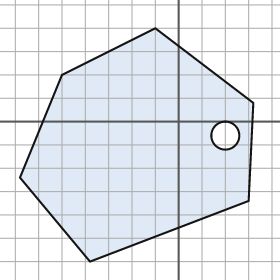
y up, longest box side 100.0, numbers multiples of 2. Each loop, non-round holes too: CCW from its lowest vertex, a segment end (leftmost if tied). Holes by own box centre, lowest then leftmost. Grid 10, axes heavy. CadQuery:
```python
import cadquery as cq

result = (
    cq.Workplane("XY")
    .moveTo(-38.0, -60.0)
    .lineTo(30.0, -34.0)
    .lineTo(32.0, 8.0)
    .lineTo(-10.0, 40.0)
    .lineTo(-50.0, 20.0)
    .lineTo(-68.0, -24.0)
    .close()
    .moveTo(20.0, -6.0)
    .circle(6.0)
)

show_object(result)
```